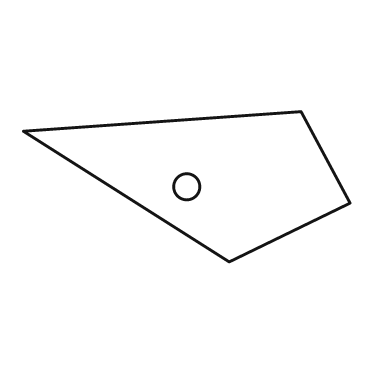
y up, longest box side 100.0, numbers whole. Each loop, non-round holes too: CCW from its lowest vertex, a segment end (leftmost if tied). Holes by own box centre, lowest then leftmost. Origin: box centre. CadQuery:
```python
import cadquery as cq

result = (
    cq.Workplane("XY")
    .moveTo(13.0, -23.0)
    .lineTo(50.0, -5.0)
    .lineTo(35.0, 23.0)
    .lineTo(-50.0, 17.0)
    .close()
    .moveTo(0.0, 0.0)
    .circle(4.0)
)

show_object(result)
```